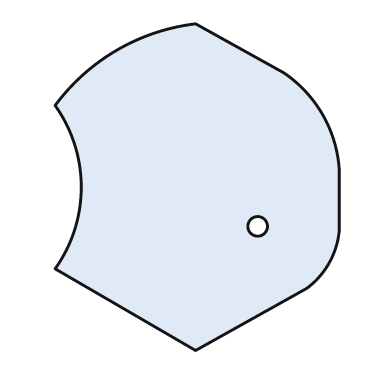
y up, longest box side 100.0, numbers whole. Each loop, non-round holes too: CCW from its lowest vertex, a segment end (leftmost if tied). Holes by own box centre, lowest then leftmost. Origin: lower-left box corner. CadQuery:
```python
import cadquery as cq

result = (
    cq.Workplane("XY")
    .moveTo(43.0, 0.0)
    .lineTo(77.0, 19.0)
    .threePointArc((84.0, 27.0), (87.0, 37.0))
    .lineTo(87.0, 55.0)
    .threePointArc((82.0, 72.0), (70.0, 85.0))
    .lineTo(43.0, 100.0)
    .threePointArc((19.0, 92.0), (0.0, 75.0))
    .threePointArc((8.0, 50.0), (0.0, 25.0))
    .close()
    .moveTo(62.0, 38.0)
    .circle(3.0)
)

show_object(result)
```